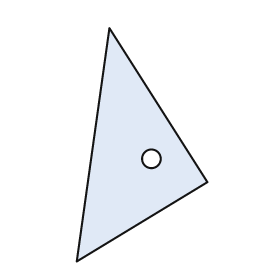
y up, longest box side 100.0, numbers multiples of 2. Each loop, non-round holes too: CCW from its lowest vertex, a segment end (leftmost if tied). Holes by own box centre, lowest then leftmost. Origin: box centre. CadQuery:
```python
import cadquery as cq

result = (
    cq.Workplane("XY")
    .moveTo(-28.0, -50.0)
    .lineTo(28.0, -16.0)
    .lineTo(-14.0, 50.0)
    .close()
    .moveTo(4.0, -6.0)
    .circle(4.0)
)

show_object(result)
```